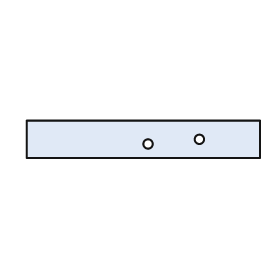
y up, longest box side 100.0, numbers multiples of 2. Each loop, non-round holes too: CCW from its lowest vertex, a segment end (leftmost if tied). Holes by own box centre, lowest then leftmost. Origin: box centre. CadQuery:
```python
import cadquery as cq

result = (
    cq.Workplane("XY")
    .moveTo(-50.0, -8.0)
    .lineTo(50.0, -8.0)
    .lineTo(50.0, 8.0)
    .lineTo(-50.0, 8.0)
    .close()
    .moveTo(2.0, -2.0)
    .circle(2.0)
    .moveTo(24.0, 0.0)
    .circle(2.0)
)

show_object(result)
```